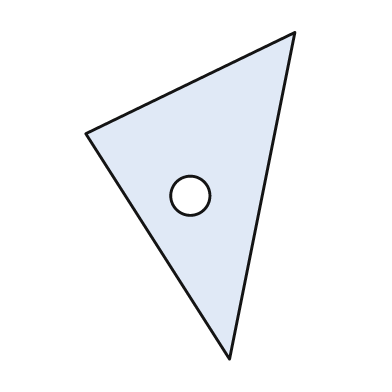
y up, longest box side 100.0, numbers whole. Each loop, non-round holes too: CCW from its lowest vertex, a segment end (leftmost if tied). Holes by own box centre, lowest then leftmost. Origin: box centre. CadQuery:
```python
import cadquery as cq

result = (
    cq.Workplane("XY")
    .moveTo(12.0, -50.0)
    .lineTo(32.0, 50.0)
    .lineTo(-32.0, 19.0)
    .close()
    .moveTo(0.0, 0.0)
    .circle(6.0)
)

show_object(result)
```